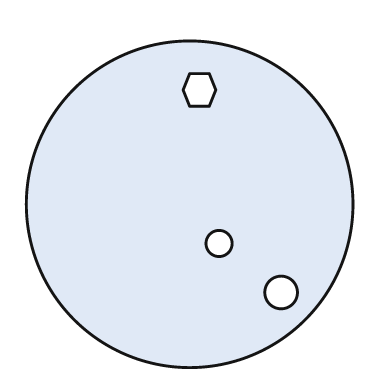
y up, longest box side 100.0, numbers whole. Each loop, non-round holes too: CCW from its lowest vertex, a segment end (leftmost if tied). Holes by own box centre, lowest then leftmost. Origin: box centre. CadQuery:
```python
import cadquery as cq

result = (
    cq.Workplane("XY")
    .moveTo(0.0, 0.0)
    .circle(50.0)
    .moveTo(28.0, -27.0)
    .circle(5.0)
    .moveTo(9.0, -12.0)
    .circle(4.0)
    .moveTo(0.0, 30.0)
    .lineTo(6.0, 30.0)
    .lineTo(8.0, 35.0)
    .lineTo(6.0, 40.0)
    .lineTo(0.0, 40.0)
    .lineTo(-2.0, 35.0)
    .close()
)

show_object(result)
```